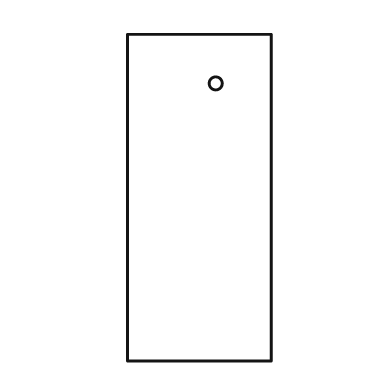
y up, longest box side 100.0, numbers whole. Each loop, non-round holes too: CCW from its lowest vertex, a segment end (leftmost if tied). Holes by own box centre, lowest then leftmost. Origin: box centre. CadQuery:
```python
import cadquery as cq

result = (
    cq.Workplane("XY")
    .moveTo(-22.0, -50.0)
    .lineTo(22.0, -50.0)
    .lineTo(22.0, 50.0)
    .lineTo(-22.0, 50.0)
    .close()
    .moveTo(5.0, 35.0)
    .circle(2.0)
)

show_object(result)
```